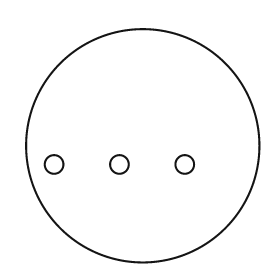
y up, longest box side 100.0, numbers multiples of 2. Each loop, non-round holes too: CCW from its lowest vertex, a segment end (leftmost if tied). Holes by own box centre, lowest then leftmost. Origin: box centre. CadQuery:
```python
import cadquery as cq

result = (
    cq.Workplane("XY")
    .moveTo(0.0, 0.0)
    .circle(50.0)
    .moveTo(-38.0, -8.0)
    .circle(4.0)
    .moveTo(-10.0, -8.0)
    .circle(4.0)
    .moveTo(18.0, -8.0)
    .circle(4.0)
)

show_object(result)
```